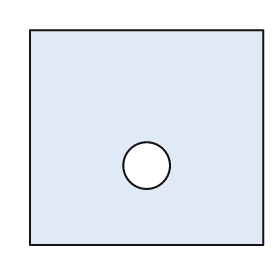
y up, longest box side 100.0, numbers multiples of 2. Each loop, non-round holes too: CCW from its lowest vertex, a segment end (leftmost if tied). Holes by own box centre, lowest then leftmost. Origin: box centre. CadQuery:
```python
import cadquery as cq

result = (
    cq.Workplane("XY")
    .moveTo(-50.0, -46.0)
    .lineTo(50.0, -46.0)
    .lineTo(50.0, 46.0)
    .lineTo(-50.0, 46.0)
    .close()
    .moveTo(0.0, -12.0)
    .circle(10.0)
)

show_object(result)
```